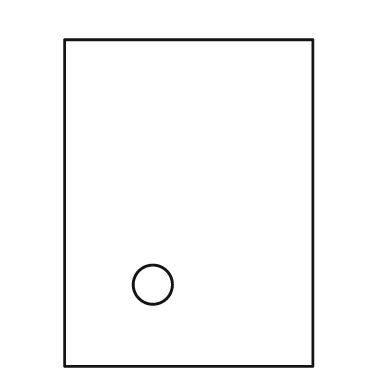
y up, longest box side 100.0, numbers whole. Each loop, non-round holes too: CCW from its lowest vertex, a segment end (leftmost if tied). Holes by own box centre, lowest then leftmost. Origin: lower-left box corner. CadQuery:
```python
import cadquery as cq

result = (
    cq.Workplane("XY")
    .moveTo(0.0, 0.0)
    .lineTo(76.0, 0.0)
    .lineTo(76.0, 100.0)
    .lineTo(0.0, 100.0)
    .close()
    .moveTo(27.0, 25.0)
    .circle(6.0)
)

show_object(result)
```